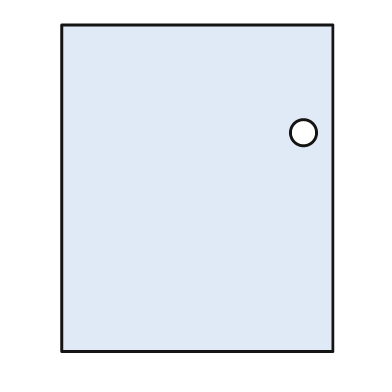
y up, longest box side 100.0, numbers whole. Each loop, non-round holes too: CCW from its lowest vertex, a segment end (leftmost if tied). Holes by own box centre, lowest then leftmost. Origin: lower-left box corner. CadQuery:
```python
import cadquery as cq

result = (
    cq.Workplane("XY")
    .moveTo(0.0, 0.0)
    .lineTo(83.0, 0.0)
    .lineTo(83.0, 100.0)
    .lineTo(0.0, 100.0)
    .close()
    .moveTo(74.0, 67.0)
    .circle(4.0)
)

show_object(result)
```